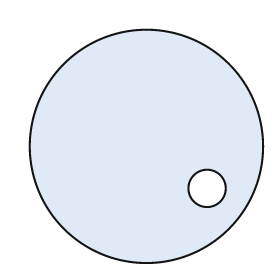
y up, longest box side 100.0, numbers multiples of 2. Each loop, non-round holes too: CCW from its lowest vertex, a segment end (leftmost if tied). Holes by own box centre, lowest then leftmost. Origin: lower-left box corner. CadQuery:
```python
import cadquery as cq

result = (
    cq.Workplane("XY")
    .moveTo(50.0, 50.0)
    .circle(50.0)
    .moveTo(76.0, 32.0)
    .circle(8.0)
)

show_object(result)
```